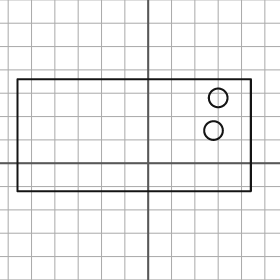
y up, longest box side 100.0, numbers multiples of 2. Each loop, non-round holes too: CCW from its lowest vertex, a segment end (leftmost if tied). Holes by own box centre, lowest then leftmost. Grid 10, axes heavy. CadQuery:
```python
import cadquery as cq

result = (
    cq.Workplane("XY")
    .moveTo(-56.0, -12.0)
    .lineTo(44.0, -12.0)
    .lineTo(44.0, 36.0)
    .lineTo(-56.0, 36.0)
    .close()
    .moveTo(28.0, 14.0)
    .circle(4.0)
    .moveTo(30.0, 28.0)
    .circle(4.0)
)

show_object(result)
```